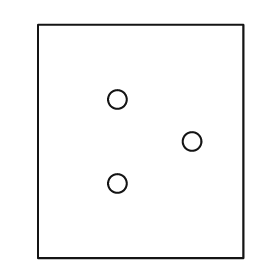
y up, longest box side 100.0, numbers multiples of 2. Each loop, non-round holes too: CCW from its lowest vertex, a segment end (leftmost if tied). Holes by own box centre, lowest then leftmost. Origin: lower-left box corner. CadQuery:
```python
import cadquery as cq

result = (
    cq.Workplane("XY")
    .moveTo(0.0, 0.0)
    .lineTo(88.0, 0.0)
    .lineTo(88.0, 100.0)
    .lineTo(0.0, 100.0)
    .close()
    .moveTo(34.0, 32.0)
    .circle(4.0)
    .moveTo(66.0, 50.0)
    .circle(4.0)
    .moveTo(34.0, 68.0)
    .circle(4.0)
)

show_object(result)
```